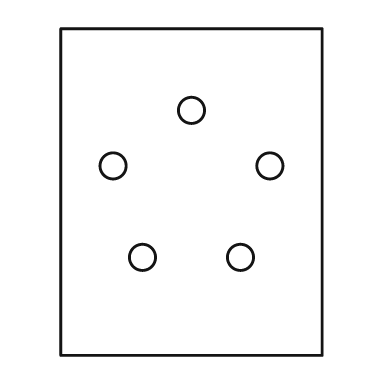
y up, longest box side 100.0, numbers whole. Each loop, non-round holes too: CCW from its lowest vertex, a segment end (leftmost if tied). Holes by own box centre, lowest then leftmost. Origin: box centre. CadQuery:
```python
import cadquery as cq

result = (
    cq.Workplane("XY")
    .moveTo(-40.0, -50.0)
    .lineTo(40.0, -50.0)
    .lineTo(40.0, 50.0)
    .lineTo(-40.0, 50.0)
    .close()
    .moveTo(-15.0, -20.0)
    .circle(4.0)
    .moveTo(15.0, -20.0)
    .circle(4.0)
    .moveTo(-24.0, 8.0)
    .circle(4.0)
    .moveTo(24.0, 8.0)
    .circle(4.0)
    .moveTo(0.0, 25.0)
    .circle(4.0)
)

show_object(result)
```